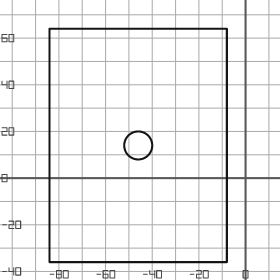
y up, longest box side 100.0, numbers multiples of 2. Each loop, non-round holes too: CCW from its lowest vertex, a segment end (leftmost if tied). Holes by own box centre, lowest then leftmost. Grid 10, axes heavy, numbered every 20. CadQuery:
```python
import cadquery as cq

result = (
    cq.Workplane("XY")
    .moveTo(-84.0, -36.0)
    .lineTo(-8.0, -36.0)
    .lineTo(-8.0, 64.0)
    .lineTo(-84.0, 64.0)
    .close()
    .moveTo(-46.0, 14.0)
    .circle(6.0)
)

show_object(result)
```